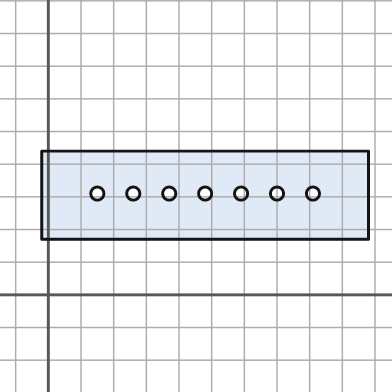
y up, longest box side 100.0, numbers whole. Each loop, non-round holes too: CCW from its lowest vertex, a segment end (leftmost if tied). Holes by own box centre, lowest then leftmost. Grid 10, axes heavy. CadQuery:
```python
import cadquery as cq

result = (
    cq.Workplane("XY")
    .moveTo(-2.0, 17.0)
    .lineTo(98.0, 17.0)
    .lineTo(98.0, 44.0)
    .lineTo(-2.0, 44.0)
    .close()
    .moveTo(15.0, 31.0)
    .circle(2.0)
    .moveTo(26.0, 31.0)
    .circle(2.0)
    .moveTo(37.0, 31.0)
    .circle(2.0)
    .moveTo(48.0, 31.0)
    .circle(2.0)
    .moveTo(59.0, 31.0)
    .circle(2.0)
    .moveTo(70.0, 31.0)
    .circle(2.0)
    .moveTo(81.0, 31.0)
    .circle(2.0)
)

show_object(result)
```